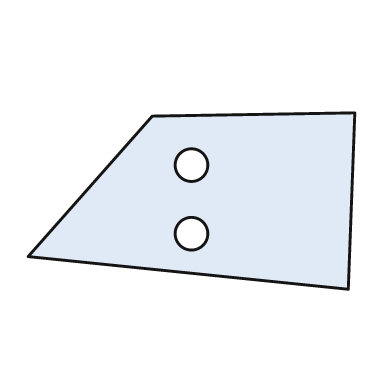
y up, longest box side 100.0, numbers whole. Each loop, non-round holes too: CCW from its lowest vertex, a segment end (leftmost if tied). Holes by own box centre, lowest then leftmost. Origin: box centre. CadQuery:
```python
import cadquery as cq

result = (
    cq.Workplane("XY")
    .moveTo(48.0, -27.0)
    .lineTo(50.0, 27.0)
    .lineTo(-12.0, 26.0)
    .lineTo(-50.0, -17.0)
    .close()
    .moveTo(0.0, -10.0)
    .circle(5.0)
    .moveTo(0.0, 11.0)
    .circle(5.0)
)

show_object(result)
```